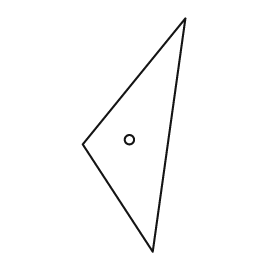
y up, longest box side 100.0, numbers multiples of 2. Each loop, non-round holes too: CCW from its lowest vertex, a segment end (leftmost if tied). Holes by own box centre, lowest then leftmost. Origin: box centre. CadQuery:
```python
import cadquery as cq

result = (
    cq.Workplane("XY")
    .moveTo(8.0, -50.0)
    .lineTo(22.0, 50.0)
    .lineTo(-22.0, -4.0)
    .close()
    .moveTo(-2.0, -2.0)
    .circle(2.0)
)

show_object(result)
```